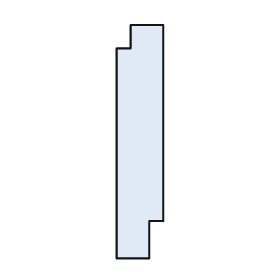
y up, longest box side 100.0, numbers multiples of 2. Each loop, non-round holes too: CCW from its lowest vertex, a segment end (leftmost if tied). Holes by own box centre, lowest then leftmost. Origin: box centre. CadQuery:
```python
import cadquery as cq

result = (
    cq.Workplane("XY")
    .moveTo(-10.0, -50.0)
    .lineTo(4.0, -50.0)
    .lineTo(4.0, -34.0)
    .lineTo(10.0, -34.0)
    .lineTo(10.0, 50.0)
    .lineTo(-4.0, 50.0)
    .lineTo(-4.0, 40.0)
    .lineTo(-10.0, 40.0)
    .close()
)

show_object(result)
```